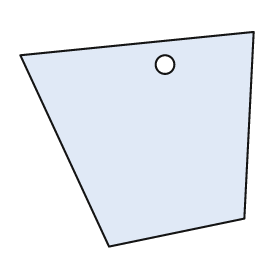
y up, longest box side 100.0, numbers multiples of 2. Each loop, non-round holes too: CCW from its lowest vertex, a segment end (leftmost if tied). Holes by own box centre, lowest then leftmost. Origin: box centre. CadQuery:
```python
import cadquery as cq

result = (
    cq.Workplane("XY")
    .moveTo(-12.0, -46.0)
    .lineTo(46.0, -34.0)
    .lineTo(50.0, 46.0)
    .lineTo(-50.0, 36.0)
    .close()
    .moveTo(12.0, 32.0)
    .circle(4.0)
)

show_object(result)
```